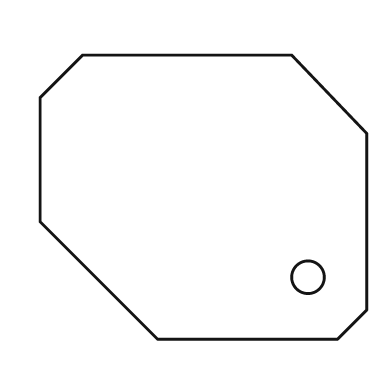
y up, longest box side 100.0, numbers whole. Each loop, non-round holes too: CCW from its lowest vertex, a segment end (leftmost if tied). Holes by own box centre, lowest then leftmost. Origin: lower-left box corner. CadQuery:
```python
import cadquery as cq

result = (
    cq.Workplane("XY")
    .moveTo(36.0, 0.0)
    .lineTo(91.0, 0.0)
    .lineTo(100.0, 9.0)
    .lineTo(100.0, 63.0)
    .lineTo(77.0, 87.0)
    .lineTo(13.0, 87.0)
    .lineTo(0.0, 74.0)
    .lineTo(0.0, 36.0)
    .close()
    .moveTo(82.0, 19.0)
    .circle(5.0)
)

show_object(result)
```